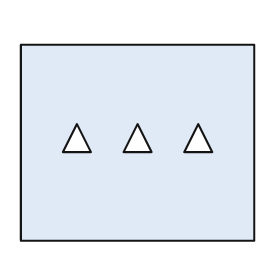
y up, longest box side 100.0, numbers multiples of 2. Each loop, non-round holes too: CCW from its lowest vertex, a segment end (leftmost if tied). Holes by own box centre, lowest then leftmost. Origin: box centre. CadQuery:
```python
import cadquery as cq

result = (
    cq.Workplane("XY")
    .moveTo(-50.0, -42.0)
    .lineTo(50.0, -42.0)
    .lineTo(50.0, 42.0)
    .lineTo(-50.0, 42.0)
    .close()
    .moveTo(-32.0, -4.0)
    .lineTo(-20.0, -4.0)
    .lineTo(-26.0, 8.0)
    .close()
    .moveTo(-6.0, -4.0)
    .lineTo(6.0, -4.0)
    .lineTo(0.0, 8.0)
    .close()
    .moveTo(20.0, -4.0)
    .lineTo(32.0, -4.0)
    .lineTo(26.0, 8.0)
    .close()
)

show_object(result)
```